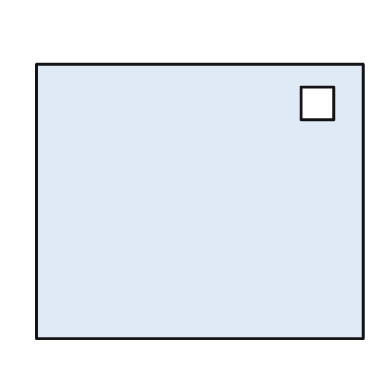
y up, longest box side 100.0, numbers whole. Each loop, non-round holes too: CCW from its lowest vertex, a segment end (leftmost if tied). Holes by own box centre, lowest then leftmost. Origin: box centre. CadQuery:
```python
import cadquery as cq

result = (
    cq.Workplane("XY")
    .moveTo(-50.0, -42.0)
    .lineTo(50.0, -42.0)
    .lineTo(50.0, 42.0)
    .lineTo(-50.0, 42.0)
    .close()
    .moveTo(31.0, 25.0)
    .lineTo(41.0, 25.0)
    .lineTo(41.0, 35.0)
    .lineTo(31.0, 35.0)
    .close()
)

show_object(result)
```